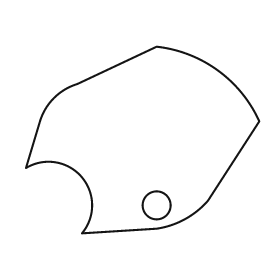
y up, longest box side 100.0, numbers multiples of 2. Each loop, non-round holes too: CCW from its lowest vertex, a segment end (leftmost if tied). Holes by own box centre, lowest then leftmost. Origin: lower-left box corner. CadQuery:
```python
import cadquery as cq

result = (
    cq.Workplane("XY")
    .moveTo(24.0, 0.0)
    .lineTo(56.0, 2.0)
    .threePointArc((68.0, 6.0), (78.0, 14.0))
    .lineTo(100.0, 48.0)
    .threePointArc((82.0, 70.0), (56.0, 80.0))
    .lineTo(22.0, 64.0)
    .threePointArc((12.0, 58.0), (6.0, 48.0))
    .lineTo(0.0, 28.0)
    .threePointArc((24.0, 24.0), (24.0, 0.0))
    .close()
    .moveTo(56.0, 12.0)
    .circle(6.0)
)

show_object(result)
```